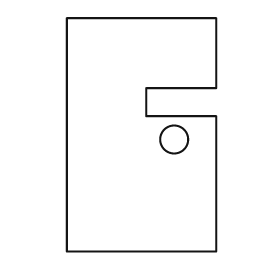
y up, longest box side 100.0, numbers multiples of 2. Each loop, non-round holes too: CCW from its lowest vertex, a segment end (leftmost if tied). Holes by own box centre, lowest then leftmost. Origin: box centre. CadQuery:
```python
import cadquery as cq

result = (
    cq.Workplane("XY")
    .moveTo(-32.0, -50.0)
    .lineTo(32.0, -50.0)
    .lineTo(32.0, 8.0)
    .lineTo(2.0, 8.0)
    .lineTo(2.0, 20.0)
    .lineTo(32.0, 20.0)
    .lineTo(32.0, 50.0)
    .lineTo(-32.0, 50.0)
    .close()
    .moveTo(14.0, -2.0)
    .circle(6.0)
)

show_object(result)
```